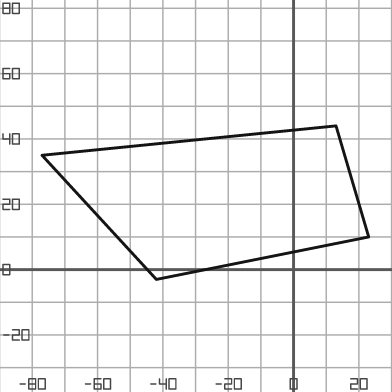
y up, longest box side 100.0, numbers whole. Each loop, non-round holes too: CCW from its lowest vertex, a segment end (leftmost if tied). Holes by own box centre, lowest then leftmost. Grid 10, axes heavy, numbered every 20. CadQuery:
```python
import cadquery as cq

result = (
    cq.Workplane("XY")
    .moveTo(-42.0, -3.0)
    .lineTo(23.0, 10.0)
    .lineTo(13.0, 44.0)
    .lineTo(-77.0, 35.0)
    .close()
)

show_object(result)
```